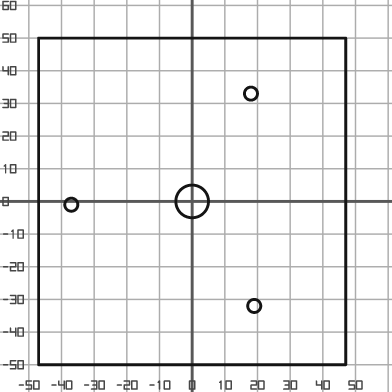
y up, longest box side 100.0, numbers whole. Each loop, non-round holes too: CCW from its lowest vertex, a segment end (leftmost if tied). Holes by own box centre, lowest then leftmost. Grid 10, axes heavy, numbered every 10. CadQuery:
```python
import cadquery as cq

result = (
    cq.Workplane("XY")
    .moveTo(-47.0, -50.0)
    .lineTo(47.0, -50.0)
    .lineTo(47.0, 50.0)
    .lineTo(-47.0, 50.0)
    .close()
    .moveTo(19.0, -32.0)
    .circle(2.0)
    .moveTo(-37.0, -1.0)
    .circle(2.0)
    .moveTo(0.0, 0.0)
    .circle(5.0)
    .moveTo(18.0, 33.0)
    .circle(2.0)
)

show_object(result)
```